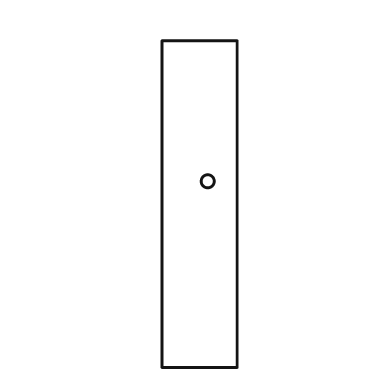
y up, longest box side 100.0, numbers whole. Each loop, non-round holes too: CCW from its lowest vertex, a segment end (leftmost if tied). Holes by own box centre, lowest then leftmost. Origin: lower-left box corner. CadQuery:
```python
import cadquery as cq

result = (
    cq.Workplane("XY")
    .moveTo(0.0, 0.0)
    .lineTo(23.0, 0.0)
    .lineTo(23.0, 100.0)
    .lineTo(0.0, 100.0)
    .close()
    .moveTo(14.0, 57.0)
    .circle(2.0)
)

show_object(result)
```